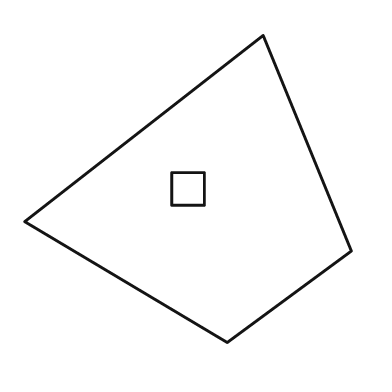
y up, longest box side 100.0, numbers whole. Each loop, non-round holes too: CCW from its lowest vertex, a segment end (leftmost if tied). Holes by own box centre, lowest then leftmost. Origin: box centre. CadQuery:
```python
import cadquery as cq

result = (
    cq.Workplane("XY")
    .moveTo(12.0, -47.0)
    .lineTo(50.0, -19.0)
    .lineTo(23.0, 47.0)
    .lineTo(-50.0, -10.0)
    .close()
    .moveTo(-5.0, -5.0)
    .lineTo(5.0, -5.0)
    .lineTo(5.0, 5.0)
    .lineTo(-5.0, 5.0)
    .close()
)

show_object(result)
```